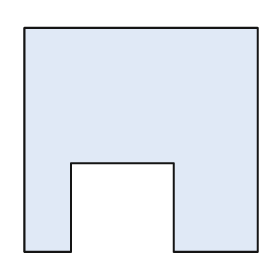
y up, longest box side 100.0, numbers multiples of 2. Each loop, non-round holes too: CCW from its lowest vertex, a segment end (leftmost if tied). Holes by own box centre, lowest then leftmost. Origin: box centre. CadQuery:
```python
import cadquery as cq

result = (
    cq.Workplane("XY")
    .moveTo(-50.0, -48.0)
    .lineTo(-30.0, -48.0)
    .lineTo(-30.0, -10.0)
    .lineTo(14.0, -10.0)
    .lineTo(14.0, -48.0)
    .lineTo(50.0, -48.0)
    .lineTo(50.0, 48.0)
    .lineTo(-50.0, 48.0)
    .close()
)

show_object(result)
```